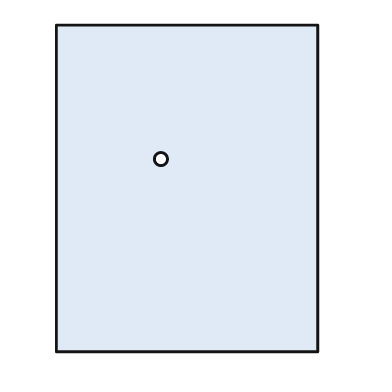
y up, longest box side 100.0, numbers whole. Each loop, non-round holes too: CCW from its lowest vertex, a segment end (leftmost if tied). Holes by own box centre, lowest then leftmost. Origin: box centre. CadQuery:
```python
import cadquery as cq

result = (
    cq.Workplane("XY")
    .moveTo(-40.0, -50.0)
    .lineTo(40.0, -50.0)
    .lineTo(40.0, 50.0)
    .lineTo(-40.0, 50.0)
    .close()
    .moveTo(-8.0, 9.0)
    .circle(2.0)
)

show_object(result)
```